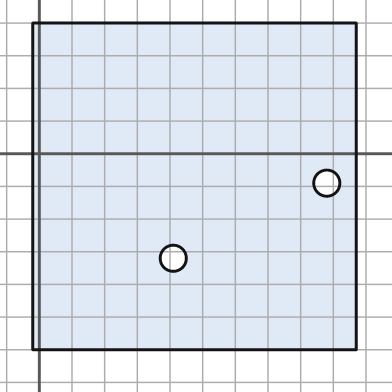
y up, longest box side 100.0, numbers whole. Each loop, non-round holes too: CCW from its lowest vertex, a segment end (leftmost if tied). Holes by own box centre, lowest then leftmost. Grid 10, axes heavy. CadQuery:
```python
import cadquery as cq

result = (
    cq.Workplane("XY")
    .moveTo(-2.0, -60.0)
    .lineTo(97.0, -60.0)
    .lineTo(97.0, 40.0)
    .lineTo(-2.0, 40.0)
    .close()
    .moveTo(41.0, -32.0)
    .circle(4.0)
    .moveTo(88.0, -9.0)
    .circle(4.0)
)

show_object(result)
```